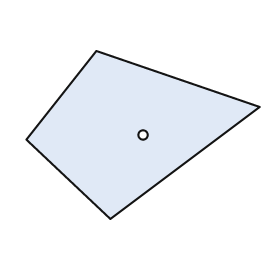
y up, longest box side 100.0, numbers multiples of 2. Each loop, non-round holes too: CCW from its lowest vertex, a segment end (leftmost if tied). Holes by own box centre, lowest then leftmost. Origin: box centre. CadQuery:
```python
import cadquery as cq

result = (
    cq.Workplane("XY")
    .moveTo(-14.0, -36.0)
    .lineTo(50.0, 12.0)
    .lineTo(-20.0, 36.0)
    .lineTo(-50.0, -2.0)
    .close()
    .moveTo(0.0, 0.0)
    .circle(2.0)
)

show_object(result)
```